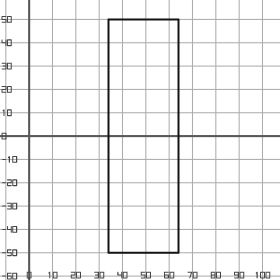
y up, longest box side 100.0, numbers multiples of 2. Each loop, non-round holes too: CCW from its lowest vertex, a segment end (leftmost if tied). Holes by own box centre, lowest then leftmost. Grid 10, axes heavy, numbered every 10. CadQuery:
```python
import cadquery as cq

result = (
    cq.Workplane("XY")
    .moveTo(34.0, -50.0)
    .lineTo(64.0, -50.0)
    .lineTo(64.0, 50.0)
    .lineTo(34.0, 50.0)
    .close()
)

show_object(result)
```